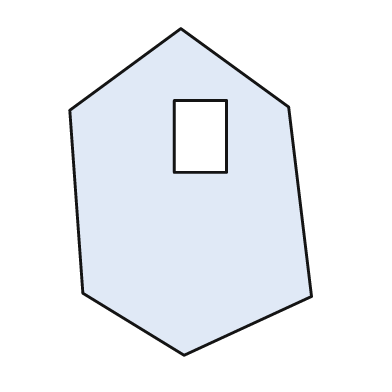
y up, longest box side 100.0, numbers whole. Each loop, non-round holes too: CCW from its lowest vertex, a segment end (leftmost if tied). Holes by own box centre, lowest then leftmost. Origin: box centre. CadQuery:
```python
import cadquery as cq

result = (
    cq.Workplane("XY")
    .moveTo(-2.0, -50.0)
    .lineTo(37.0, -32.0)
    .lineTo(30.0, 26.0)
    .lineTo(-3.0, 50.0)
    .lineTo(-37.0, 25.0)
    .lineTo(-33.0, -31.0)
    .close()
    .moveTo(-5.0, 6.0)
    .lineTo(11.0, 6.0)
    .lineTo(11.0, 28.0)
    .lineTo(-5.0, 28.0)
    .close()
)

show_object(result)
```